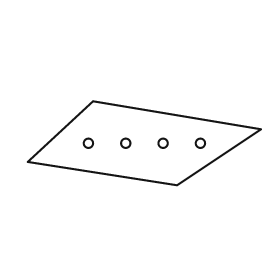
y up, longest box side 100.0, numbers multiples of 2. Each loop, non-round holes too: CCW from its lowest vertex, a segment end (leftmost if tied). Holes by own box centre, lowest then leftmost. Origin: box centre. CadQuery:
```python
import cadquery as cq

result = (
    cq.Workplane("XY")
    .moveTo(14.0, -18.0)
    .lineTo(50.0, 6.0)
    .lineTo(-22.0, 18.0)
    .lineTo(-50.0, -8.0)
    .close()
    .moveTo(-24.0, 0.0)
    .circle(2.0)
    .moveTo(-8.0, 0.0)
    .circle(2.0)
    .moveTo(8.0, 0.0)
    .circle(2.0)
    .moveTo(24.0, 0.0)
    .circle(2.0)
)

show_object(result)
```